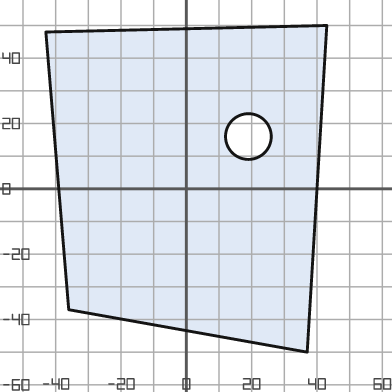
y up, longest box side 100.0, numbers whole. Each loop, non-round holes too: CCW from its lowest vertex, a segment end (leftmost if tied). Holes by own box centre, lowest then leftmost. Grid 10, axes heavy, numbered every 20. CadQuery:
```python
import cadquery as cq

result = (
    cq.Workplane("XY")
    .moveTo(37.0, -50.0)
    .lineTo(43.0, 50.0)
    .lineTo(-43.0, 48.0)
    .lineTo(-36.0, -37.0)
    .close()
    .moveTo(19.0, 16.0)
    .circle(7.0)
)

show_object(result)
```